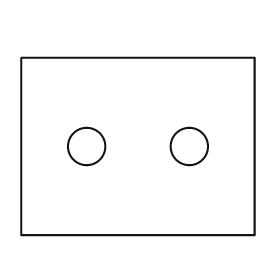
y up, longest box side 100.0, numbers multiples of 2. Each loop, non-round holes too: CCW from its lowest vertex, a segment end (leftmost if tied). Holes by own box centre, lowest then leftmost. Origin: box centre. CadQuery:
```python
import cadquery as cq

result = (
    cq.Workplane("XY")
    .moveTo(-50.0, -38.0)
    .lineTo(50.0, -38.0)
    .lineTo(50.0, 38.0)
    .lineTo(-50.0, 38.0)
    .close()
    .moveTo(-22.0, 0.0)
    .circle(8.0)
    .moveTo(22.0, 0.0)
    .circle(8.0)
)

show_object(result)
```